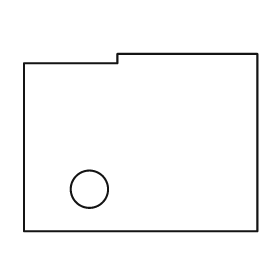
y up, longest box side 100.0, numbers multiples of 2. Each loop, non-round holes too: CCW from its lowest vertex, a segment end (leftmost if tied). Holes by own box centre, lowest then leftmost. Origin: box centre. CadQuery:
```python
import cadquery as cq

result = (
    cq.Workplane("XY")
    .moveTo(-50.0, -38.0)
    .lineTo(50.0, -38.0)
    .lineTo(50.0, 38.0)
    .lineTo(-10.0, 38.0)
    .lineTo(-10.0, 34.0)
    .lineTo(-50.0, 34.0)
    .close()
    .moveTo(-22.0, -20.0)
    .circle(8.0)
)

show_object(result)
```